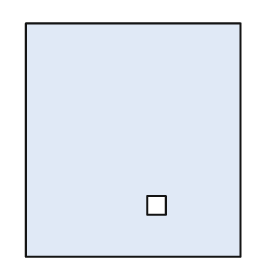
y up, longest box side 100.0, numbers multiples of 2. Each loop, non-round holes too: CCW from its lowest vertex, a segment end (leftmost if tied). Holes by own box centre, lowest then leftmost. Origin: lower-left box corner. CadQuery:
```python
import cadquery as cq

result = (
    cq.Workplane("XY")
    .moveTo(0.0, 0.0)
    .lineTo(92.0, 0.0)
    .lineTo(92.0, 100.0)
    .lineTo(0.0, 100.0)
    .close()
    .moveTo(52.0, 18.0)
    .lineTo(60.0, 18.0)
    .lineTo(60.0, 26.0)
    .lineTo(52.0, 26.0)
    .close()
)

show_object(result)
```